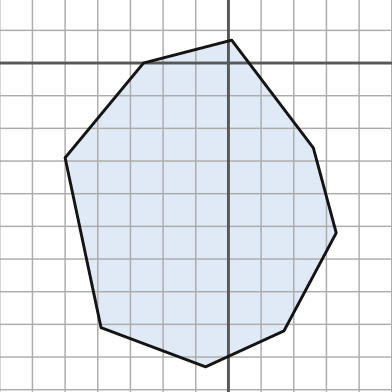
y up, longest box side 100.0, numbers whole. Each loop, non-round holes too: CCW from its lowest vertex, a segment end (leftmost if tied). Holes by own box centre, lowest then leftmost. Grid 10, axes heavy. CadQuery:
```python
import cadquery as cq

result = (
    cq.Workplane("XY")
    .moveTo(-7.0, -93.0)
    .lineTo(17.0, -82.0)
    .lineTo(33.0, -52.0)
    .lineTo(26.0, -26.0)
    .lineTo(1.0, 7.0)
    .lineTo(-26.0, 0.0)
    .lineTo(-50.0, -29.0)
    .lineTo(-39.0, -81.0)
    .close()
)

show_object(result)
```